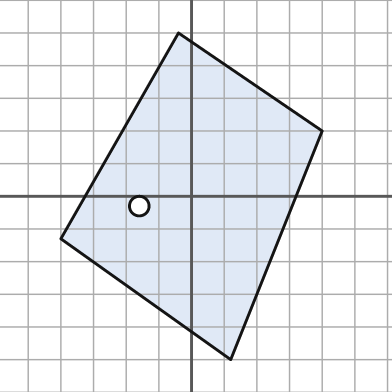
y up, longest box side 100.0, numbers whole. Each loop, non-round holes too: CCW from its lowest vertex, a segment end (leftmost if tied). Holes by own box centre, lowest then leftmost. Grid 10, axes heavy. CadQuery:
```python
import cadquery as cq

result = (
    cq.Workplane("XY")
    .moveTo(12.0, -50.0)
    .lineTo(40.0, 20.0)
    .lineTo(-4.0, 50.0)
    .lineTo(-40.0, -13.0)
    .close()
    .moveTo(-16.0, -3.0)
    .circle(3.0)
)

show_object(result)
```